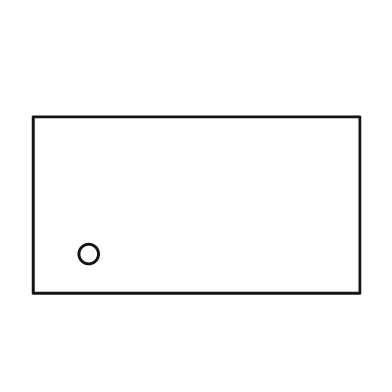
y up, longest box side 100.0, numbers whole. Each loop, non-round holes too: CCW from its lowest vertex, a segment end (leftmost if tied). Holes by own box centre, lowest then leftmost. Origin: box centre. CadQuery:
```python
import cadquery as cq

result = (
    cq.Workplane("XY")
    .moveTo(-50.0, -27.0)
    .lineTo(50.0, -27.0)
    .lineTo(50.0, 27.0)
    .lineTo(-50.0, 27.0)
    .close()
    .moveTo(-33.0, -15.0)
    .circle(3.0)
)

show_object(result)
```